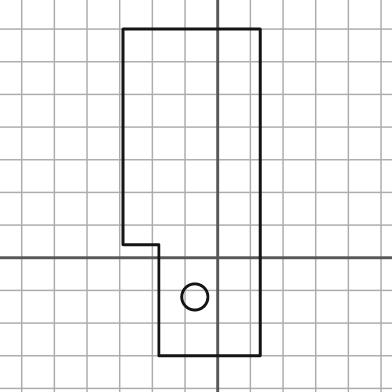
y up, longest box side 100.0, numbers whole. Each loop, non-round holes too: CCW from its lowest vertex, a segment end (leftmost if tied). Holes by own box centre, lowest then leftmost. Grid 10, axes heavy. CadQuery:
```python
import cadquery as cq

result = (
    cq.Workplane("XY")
    .moveTo(-18.0, -30.0)
    .lineTo(13.0, -30.0)
    .lineTo(13.0, 70.0)
    .lineTo(-29.0, 70.0)
    .lineTo(-29.0, 4.0)
    .lineTo(-18.0, 4.0)
    .close()
    .moveTo(-7.0, -12.0)
    .circle(4.0)
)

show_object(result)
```